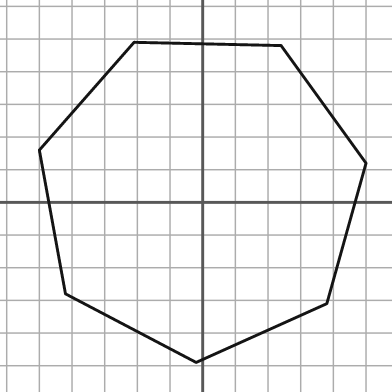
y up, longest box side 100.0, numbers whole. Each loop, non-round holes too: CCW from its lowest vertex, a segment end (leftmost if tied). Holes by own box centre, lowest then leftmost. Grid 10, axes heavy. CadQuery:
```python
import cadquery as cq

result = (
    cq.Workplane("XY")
    .moveTo(-2.0, -49.0)
    .lineTo(38.0, -31.0)
    .lineTo(50.0, 12.0)
    .lineTo(24.0, 48.0)
    .lineTo(-21.0, 49.0)
    .lineTo(-50.0, 16.0)
    .lineTo(-42.0, -28.0)
    .close()
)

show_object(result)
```